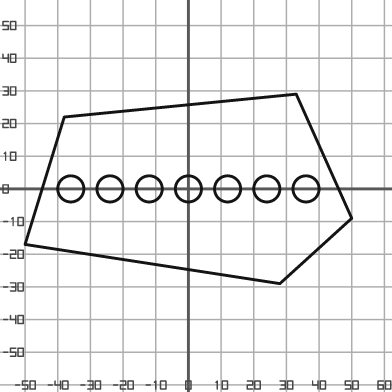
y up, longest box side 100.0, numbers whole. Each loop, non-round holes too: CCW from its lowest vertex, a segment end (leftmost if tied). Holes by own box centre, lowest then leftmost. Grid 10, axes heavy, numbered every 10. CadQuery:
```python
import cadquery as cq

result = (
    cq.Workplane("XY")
    .moveTo(28.0, -29.0)
    .lineTo(50.0, -9.0)
    .lineTo(33.0, 29.0)
    .lineTo(-38.0, 22.0)
    .lineTo(-50.0, -17.0)
    .close()
    .moveTo(-36.0, 0.0)
    .circle(4.0)
    .moveTo(-24.0, 0.0)
    .circle(4.0)
    .moveTo(-12.0, 0.0)
    .circle(4.0)
    .moveTo(0.0, 0.0)
    .circle(4.0)
    .moveTo(12.0, 0.0)
    .circle(4.0)
    .moveTo(24.0, 0.0)
    .circle(4.0)
    .moveTo(36.0, 0.0)
    .circle(4.0)
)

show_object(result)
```